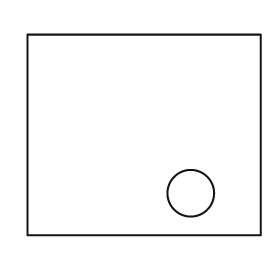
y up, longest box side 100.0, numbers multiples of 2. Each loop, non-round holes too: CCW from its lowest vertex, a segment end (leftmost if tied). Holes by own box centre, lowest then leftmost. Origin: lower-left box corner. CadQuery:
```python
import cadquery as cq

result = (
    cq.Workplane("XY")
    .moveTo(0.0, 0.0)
    .lineTo(100.0, 0.0)
    .lineTo(100.0, 86.0)
    .lineTo(0.0, 86.0)
    .close()
    .moveTo(70.0, 18.0)
    .circle(10.0)
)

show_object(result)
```